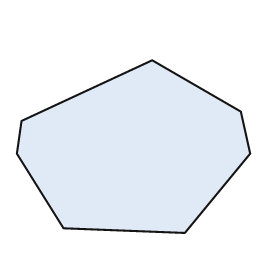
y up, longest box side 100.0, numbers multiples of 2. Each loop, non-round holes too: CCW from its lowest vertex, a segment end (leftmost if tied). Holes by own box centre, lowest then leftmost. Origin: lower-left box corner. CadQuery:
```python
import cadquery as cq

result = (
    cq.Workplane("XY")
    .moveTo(72.0, 0.0)
    .lineTo(100.0, 34.0)
    .lineTo(96.0, 52.0)
    .lineTo(58.0, 74.0)
    .lineTo(2.0, 48.0)
    .lineTo(0.0, 34.0)
    .lineTo(20.0, 2.0)
    .close()
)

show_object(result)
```